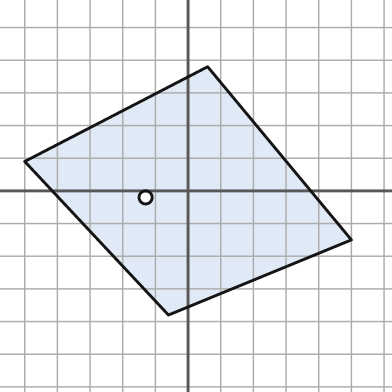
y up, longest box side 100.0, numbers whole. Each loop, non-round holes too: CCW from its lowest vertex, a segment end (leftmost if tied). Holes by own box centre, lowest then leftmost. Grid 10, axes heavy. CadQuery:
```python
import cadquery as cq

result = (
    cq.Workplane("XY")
    .moveTo(-6.0, -38.0)
    .lineTo(50.0, -15.0)
    .lineTo(6.0, 38.0)
    .lineTo(-50.0, 9.0)
    .close()
    .moveTo(-13.0, -2.0)
    .circle(2.0)
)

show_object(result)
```